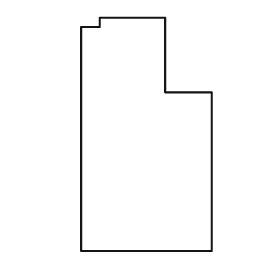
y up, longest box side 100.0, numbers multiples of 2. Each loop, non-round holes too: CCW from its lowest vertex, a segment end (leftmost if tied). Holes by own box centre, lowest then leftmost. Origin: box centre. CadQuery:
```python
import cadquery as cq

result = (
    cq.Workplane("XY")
    .moveTo(-28.0, -50.0)
    .lineTo(28.0, -50.0)
    .lineTo(28.0, 18.0)
    .lineTo(8.0, 18.0)
    .lineTo(8.0, 50.0)
    .lineTo(-20.0, 50.0)
    .lineTo(-20.0, 46.0)
    .lineTo(-28.0, 46.0)
    .close()
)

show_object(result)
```